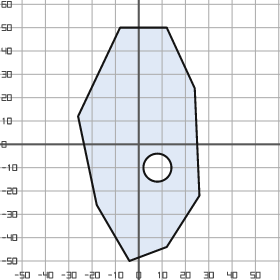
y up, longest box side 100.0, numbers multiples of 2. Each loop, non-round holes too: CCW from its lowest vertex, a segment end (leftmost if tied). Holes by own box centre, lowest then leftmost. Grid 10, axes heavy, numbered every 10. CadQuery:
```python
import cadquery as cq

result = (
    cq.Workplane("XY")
    .moveTo(-4.0, -50.0)
    .lineTo(12.0, -44.0)
    .lineTo(26.0, -22.0)
    .lineTo(24.0, 24.0)
    .lineTo(12.0, 50.0)
    .lineTo(-8.0, 50.0)
    .lineTo(-26.0, 12.0)
    .lineTo(-18.0, -26.0)
    .close()
    .moveTo(8.0, -10.0)
    .circle(6.0)
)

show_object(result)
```